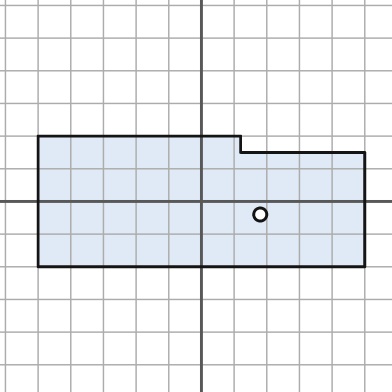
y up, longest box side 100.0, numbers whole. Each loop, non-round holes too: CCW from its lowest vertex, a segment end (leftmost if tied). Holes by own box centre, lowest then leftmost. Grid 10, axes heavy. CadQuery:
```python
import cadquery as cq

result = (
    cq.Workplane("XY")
    .moveTo(-50.0, -20.0)
    .lineTo(50.0, -20.0)
    .lineTo(50.0, 15.0)
    .lineTo(12.0, 15.0)
    .lineTo(12.0, 20.0)
    .lineTo(-50.0, 20.0)
    .close()
    .moveTo(18.0, -4.0)
    .circle(2.0)
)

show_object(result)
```